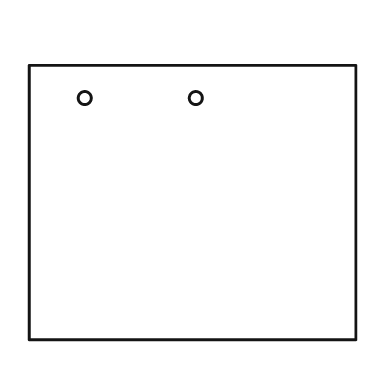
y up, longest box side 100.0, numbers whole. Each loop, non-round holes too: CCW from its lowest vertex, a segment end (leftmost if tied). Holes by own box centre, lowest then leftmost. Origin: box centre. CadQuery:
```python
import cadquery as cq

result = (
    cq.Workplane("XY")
    .moveTo(-50.0, -42.0)
    .lineTo(50.0, -42.0)
    .lineTo(50.0, 42.0)
    .lineTo(-50.0, 42.0)
    .close()
    .moveTo(-33.0, 32.0)
    .circle(2.0)
    .moveTo(1.0, 32.0)
    .circle(2.0)
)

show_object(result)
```